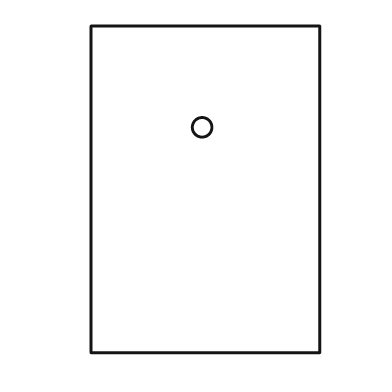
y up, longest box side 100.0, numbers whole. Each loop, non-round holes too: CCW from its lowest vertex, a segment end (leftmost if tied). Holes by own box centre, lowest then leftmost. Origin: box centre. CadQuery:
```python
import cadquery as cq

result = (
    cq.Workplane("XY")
    .moveTo(-35.0, -50.0)
    .lineTo(35.0, -50.0)
    .lineTo(35.0, 50.0)
    .lineTo(-35.0, 50.0)
    .close()
    .moveTo(-1.0, 19.0)
    .circle(3.0)
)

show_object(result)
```